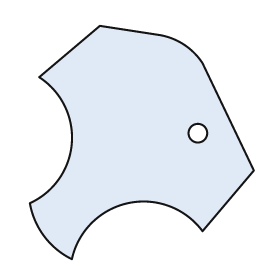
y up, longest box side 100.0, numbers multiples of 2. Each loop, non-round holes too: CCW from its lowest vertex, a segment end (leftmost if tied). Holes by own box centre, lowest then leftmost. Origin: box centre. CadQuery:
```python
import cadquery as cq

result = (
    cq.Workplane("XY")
    .moveTo(-30.0, -50.0)
    .threePointArc((-6.0, -26.0), (26.0, -38.0))
    .lineTo(48.0, -12.0)
    .lineTo(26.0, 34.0)
    .threePointArc((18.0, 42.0), (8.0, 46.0))
    .lineTo(-18.0, 50.0)
    .lineTo(-44.0, 28.0)
    .threePointArc((-30.0, 0.0), (-48.0, -26.0))
    .threePointArc((-42.0, -40.0), (-30.0, -50.0))
    .close()
    .moveTo(24.0, 4.0)
    .circle(4.0)
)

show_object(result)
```